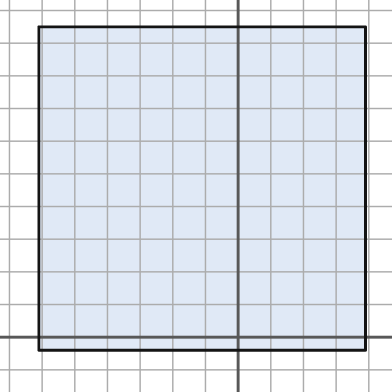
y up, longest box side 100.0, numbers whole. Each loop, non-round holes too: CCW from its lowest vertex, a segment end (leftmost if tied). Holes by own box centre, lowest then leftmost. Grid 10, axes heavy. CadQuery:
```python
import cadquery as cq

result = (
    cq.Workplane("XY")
    .moveTo(-61.0, -4.0)
    .lineTo(39.0, -4.0)
    .lineTo(39.0, 95.0)
    .lineTo(-61.0, 95.0)
    .close()
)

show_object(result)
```